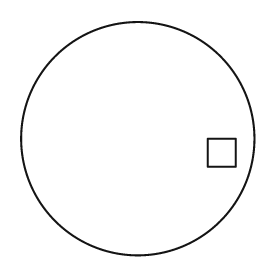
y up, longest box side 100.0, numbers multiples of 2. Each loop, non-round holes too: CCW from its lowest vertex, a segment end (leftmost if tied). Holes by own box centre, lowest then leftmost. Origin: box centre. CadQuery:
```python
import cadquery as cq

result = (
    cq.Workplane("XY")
    .moveTo(0.0, 0.0)
    .circle(50.0)
    .moveTo(30.0, -12.0)
    .lineTo(42.0, -12.0)
    .lineTo(42.0, 0.0)
    .lineTo(30.0, 0.0)
    .close()
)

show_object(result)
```